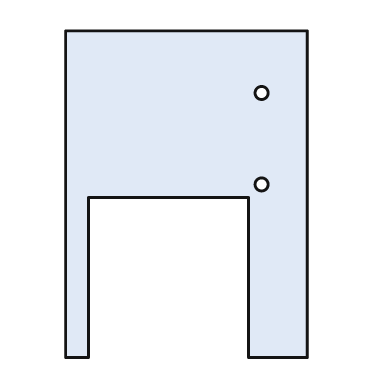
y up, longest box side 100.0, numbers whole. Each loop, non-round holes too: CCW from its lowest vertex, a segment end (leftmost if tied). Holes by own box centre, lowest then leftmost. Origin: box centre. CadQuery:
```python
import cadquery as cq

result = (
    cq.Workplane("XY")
    .moveTo(-37.0, -50.0)
    .lineTo(-30.0, -50.0)
    .lineTo(-30.0, -1.0)
    .lineTo(19.0, -1.0)
    .lineTo(19.0, -50.0)
    .lineTo(37.0, -50.0)
    .lineTo(37.0, 50.0)
    .lineTo(-37.0, 50.0)
    .close()
    .moveTo(23.0, 3.0)
    .circle(2.0)
    .moveTo(23.0, 31.0)
    .circle(2.0)
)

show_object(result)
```